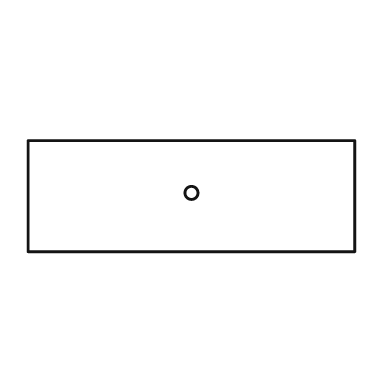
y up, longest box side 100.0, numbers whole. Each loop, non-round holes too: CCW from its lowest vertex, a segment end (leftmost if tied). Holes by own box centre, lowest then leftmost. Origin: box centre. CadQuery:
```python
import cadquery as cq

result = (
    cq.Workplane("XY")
    .moveTo(-50.0, -17.0)
    .lineTo(50.0, -17.0)
    .lineTo(50.0, 17.0)
    .lineTo(-50.0, 17.0)
    .close()
    .moveTo(0.0, 1.0)
    .circle(2.0)
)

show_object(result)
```